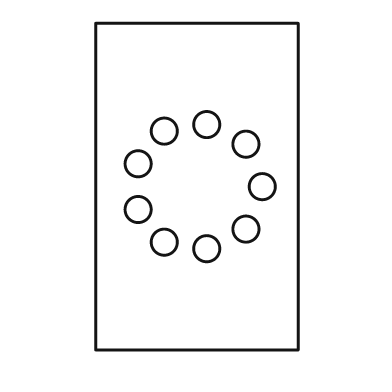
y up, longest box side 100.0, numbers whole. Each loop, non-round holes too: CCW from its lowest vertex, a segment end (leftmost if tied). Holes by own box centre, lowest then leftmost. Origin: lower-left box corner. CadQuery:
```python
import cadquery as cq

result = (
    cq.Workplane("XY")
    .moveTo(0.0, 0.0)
    .lineTo(62.0, 0.0)
    .lineTo(62.0, 100.0)
    .lineTo(0.0, 100.0)
    .close()
    .moveTo(34.0, 31.0)
    .circle(4.0)
    .moveTo(21.0, 33.0)
    .circle(4.0)
    .moveTo(46.0, 37.0)
    .circle(4.0)
    .moveTo(13.0, 43.0)
    .circle(4.0)
    .moveTo(51.0, 50.0)
    .circle(4.0)
    .moveTo(13.0, 57.0)
    .circle(4.0)
    .moveTo(46.0, 63.0)
    .circle(4.0)
    .moveTo(21.0, 67.0)
    .circle(4.0)
    .moveTo(34.0, 69.0)
    .circle(4.0)
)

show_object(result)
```